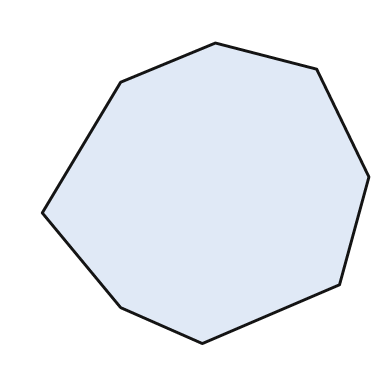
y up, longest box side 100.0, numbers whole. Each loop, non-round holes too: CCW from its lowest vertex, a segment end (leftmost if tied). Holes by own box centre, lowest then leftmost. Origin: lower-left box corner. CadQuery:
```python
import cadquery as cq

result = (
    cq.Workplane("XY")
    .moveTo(49.0, 0.0)
    .lineTo(91.0, 18.0)
    .lineTo(100.0, 51.0)
    .lineTo(84.0, 84.0)
    .lineTo(53.0, 92.0)
    .lineTo(24.0, 80.0)
    .lineTo(0.0, 40.0)
    .lineTo(24.0, 11.0)
    .close()
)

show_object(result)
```